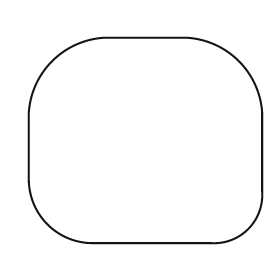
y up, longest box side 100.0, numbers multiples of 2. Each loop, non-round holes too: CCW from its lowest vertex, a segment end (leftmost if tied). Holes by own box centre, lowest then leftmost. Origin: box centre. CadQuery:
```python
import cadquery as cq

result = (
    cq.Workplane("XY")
    .moveTo(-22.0, -44.0)
    .lineTo(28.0, -44.0)
    .threePointArc((44.0, -38.0), (50.0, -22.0))
    .lineTo(50.0, 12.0)
    .threePointArc((40.0, 34.0), (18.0, 44.0))
    .lineTo(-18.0, 44.0)
    .threePointArc((-40.0, 34.0), (-50.0, 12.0))
    .lineTo(-50.0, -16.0)
    .threePointArc((-42.0, -36.0), (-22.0, -44.0))
    .close()
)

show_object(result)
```